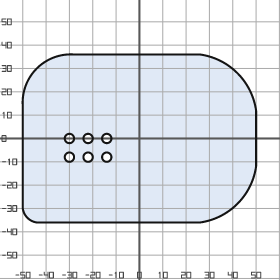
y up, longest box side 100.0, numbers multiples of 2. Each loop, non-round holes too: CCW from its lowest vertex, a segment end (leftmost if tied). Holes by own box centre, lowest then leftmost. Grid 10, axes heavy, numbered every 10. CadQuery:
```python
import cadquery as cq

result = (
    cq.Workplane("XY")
    .moveTo(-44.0, -36.0)
    .lineTo(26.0, -36.0)
    .threePointArc((42.0, -28.0), (50.0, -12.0))
    .lineTo(50.0, 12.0)
    .threePointArc((42.0, 28.0), (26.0, 36.0))
    .lineTo(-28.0, 36.0)
    .threePointArc((-44.0, 30.0), (-50.0, 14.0))
    .lineTo(-50.0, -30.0)
    .threePointArc((-48.0, -34.0), (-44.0, -36.0))
    .close()
    .moveTo(-30.0, -8.0)
    .circle(2.0)
    .moveTo(-22.0, -8.0)
    .circle(2.0)
    .moveTo(-14.0, -8.0)
    .circle(2.0)
    .moveTo(-30.0, 0.0)
    .circle(2.0)
    .moveTo(-22.0, 0.0)
    .circle(2.0)
    .moveTo(-14.0, 0.0)
    .circle(2.0)
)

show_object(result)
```